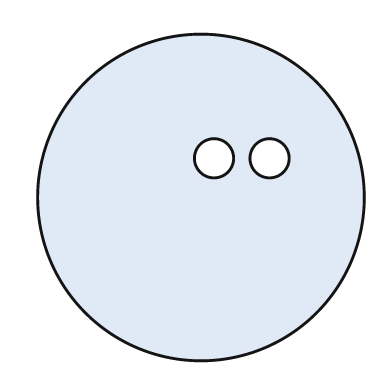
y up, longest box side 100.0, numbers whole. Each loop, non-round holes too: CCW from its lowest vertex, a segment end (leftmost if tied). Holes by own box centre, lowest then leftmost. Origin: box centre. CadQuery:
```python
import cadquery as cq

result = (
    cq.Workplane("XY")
    .moveTo(0.0, 0.0)
    .circle(50.0)
    .moveTo(4.0, 12.0)
    .circle(6.0)
    .moveTo(21.0, 12.0)
    .circle(6.0)
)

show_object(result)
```